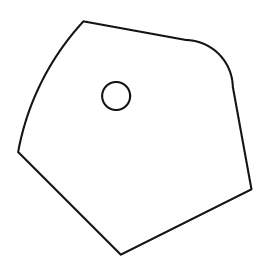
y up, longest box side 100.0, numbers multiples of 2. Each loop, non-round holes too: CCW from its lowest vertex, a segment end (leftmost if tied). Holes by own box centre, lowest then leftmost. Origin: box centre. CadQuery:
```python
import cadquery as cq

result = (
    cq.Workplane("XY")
    .moveTo(-6.0, -50.0)
    .lineTo(50.0, -22.0)
    .lineTo(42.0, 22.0)
    .threePointArc((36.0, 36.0), (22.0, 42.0))
    .lineTo(-22.0, 50.0)
    .threePointArc((-40.0, 24.0), (-50.0, -6.0))
    .close()
    .moveTo(-8.0, 18.0)
    .circle(6.0)
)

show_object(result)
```